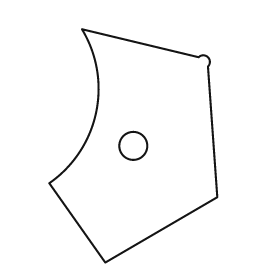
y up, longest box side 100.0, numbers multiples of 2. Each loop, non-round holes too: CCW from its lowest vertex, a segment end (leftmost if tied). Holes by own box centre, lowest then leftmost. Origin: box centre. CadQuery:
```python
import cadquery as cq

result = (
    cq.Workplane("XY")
    .moveTo(-12.0, -50.0)
    .lineTo(36.0, -22.0)
    .lineTo(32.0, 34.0)
    .threePointArc((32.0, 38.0), (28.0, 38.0))
    .lineTo(-22.0, 50.0)
    .threePointArc((-16.0, 14.0), (-36.0, -16.0))
    .close()
    .moveTo(0.0, 0.0)
    .circle(6.0)
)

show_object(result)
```